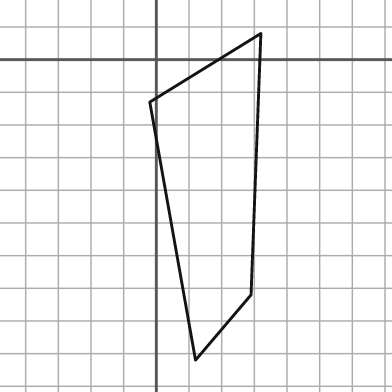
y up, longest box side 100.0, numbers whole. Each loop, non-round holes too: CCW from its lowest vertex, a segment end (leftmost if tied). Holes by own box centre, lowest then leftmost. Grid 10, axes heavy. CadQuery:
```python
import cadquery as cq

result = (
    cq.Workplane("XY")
    .moveTo(12.0, -92.0)
    .lineTo(29.0, -72.0)
    .lineTo(32.0, 8.0)
    .lineTo(-2.0, -13.0)
    .close()
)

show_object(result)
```